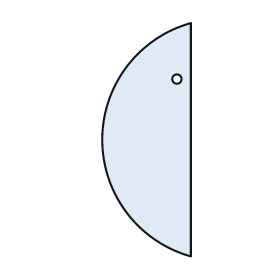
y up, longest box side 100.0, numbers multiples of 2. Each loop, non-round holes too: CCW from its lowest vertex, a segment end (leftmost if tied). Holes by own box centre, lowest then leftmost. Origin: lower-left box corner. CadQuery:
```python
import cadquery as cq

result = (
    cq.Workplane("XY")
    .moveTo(38.0, 0.0)
    .lineTo(38.0, 100.0)
    .threePointArc((0.0, 50.0), (38.0, 0.0))
    .close()
    .moveTo(32.0, 76.0)
    .circle(2.0)
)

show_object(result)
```